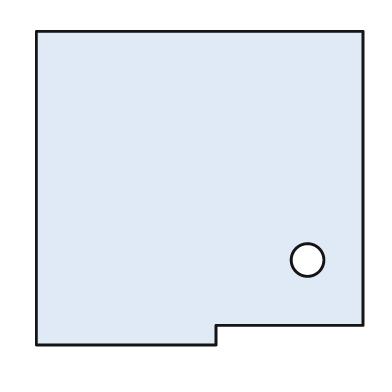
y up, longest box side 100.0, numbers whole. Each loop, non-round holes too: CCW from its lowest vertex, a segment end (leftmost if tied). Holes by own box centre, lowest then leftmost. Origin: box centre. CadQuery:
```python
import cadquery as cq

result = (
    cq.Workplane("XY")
    .moveTo(-50.0, -48.0)
    .lineTo(5.0, -48.0)
    .lineTo(5.0, -42.0)
    .lineTo(50.0, -42.0)
    .lineTo(50.0, 48.0)
    .lineTo(-50.0, 48.0)
    .close()
    .moveTo(33.0, -22.0)
    .circle(5.0)
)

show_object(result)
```